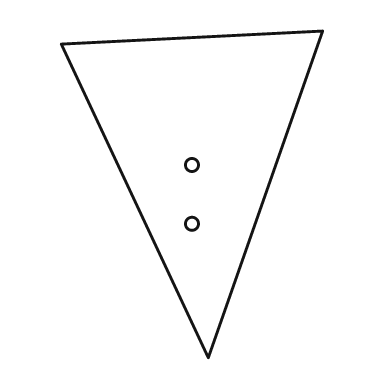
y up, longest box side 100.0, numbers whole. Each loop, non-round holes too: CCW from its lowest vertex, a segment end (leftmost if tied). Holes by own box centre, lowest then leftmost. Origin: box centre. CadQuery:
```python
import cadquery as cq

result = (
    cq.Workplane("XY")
    .moveTo(5.0, -50.0)
    .lineTo(40.0, 50.0)
    .lineTo(-40.0, 46.0)
    .close()
    .moveTo(0.0, -9.0)
    .circle(2.0)
    .moveTo(0.0, 9.0)
    .circle(2.0)
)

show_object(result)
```